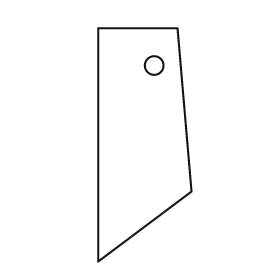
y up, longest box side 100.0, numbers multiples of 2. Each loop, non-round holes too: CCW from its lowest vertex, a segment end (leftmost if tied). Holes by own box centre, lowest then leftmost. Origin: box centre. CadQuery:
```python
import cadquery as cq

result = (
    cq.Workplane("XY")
    .moveTo(-20.0, -50.0)
    .lineTo(20.0, -20.0)
    .lineTo(14.0, 50.0)
    .lineTo(-20.0, 50.0)
    .close()
    .moveTo(4.0, 34.0)
    .circle(4.0)
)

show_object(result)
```